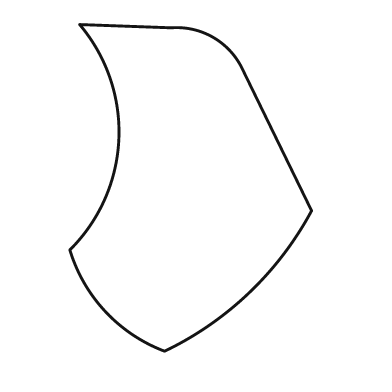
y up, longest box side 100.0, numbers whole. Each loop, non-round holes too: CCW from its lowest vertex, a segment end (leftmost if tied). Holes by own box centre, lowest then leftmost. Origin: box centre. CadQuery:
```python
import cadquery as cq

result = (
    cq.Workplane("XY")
    .moveTo(-8.0, -50.0)
    .threePointArc((18.0, -32.0), (37.0, -7.0))
    .lineTo(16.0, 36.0)
    .threePointArc((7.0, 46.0), (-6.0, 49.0))
    .lineTo(-34.0, 50.0)
    .threePointArc((-22.0, 15.0), (-37.0, -19.0))
    .threePointArc((-26.0, -38.0), (-8.0, -50.0))
    .close()
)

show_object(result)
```